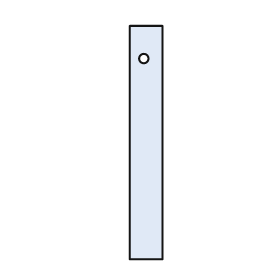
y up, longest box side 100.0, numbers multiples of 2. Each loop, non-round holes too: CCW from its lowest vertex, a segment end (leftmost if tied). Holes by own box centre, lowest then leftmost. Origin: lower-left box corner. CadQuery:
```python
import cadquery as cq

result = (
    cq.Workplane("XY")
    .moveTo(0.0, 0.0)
    .lineTo(14.0, 0.0)
    .lineTo(14.0, 100.0)
    .lineTo(0.0, 100.0)
    .close()
    .moveTo(6.0, 86.0)
    .circle(2.0)
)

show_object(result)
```